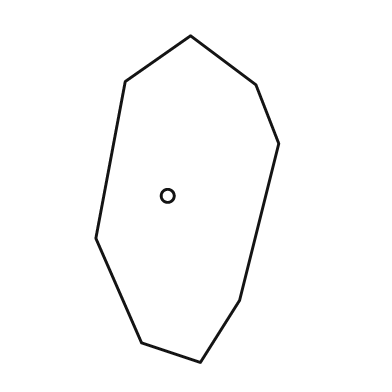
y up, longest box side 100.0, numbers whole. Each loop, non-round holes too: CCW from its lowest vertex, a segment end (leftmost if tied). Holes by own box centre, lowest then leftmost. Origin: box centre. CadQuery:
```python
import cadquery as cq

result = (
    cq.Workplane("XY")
    .moveTo(4.0, -50.0)
    .lineTo(16.0, -31.0)
    .lineTo(28.0, 17.0)
    .lineTo(21.0, 35.0)
    .lineTo(1.0, 50.0)
    .lineTo(-19.0, 36.0)
    .lineTo(-28.0, -12.0)
    .lineTo(-14.0, -44.0)
    .close()
    .moveTo(-6.0, 1.0)
    .circle(2.0)
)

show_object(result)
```